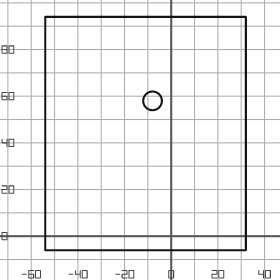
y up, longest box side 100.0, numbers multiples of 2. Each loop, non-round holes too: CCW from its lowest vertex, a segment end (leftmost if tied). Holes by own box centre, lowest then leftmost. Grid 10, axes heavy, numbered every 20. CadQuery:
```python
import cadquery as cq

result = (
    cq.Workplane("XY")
    .moveTo(-54.0, -6.0)
    .lineTo(32.0, -6.0)
    .lineTo(32.0, 94.0)
    .lineTo(-54.0, 94.0)
    .close()
    .moveTo(-8.0, 58.0)
    .circle(4.0)
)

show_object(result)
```